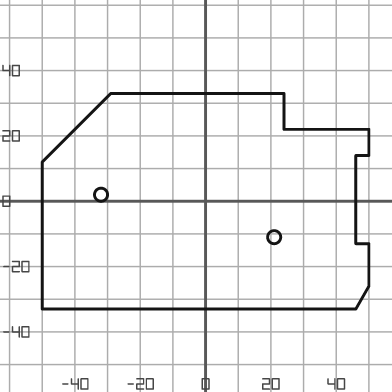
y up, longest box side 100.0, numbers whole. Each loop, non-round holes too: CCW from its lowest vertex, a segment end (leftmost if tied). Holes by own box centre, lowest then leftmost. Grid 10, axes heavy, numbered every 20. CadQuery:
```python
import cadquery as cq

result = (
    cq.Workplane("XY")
    .moveTo(-50.0, -33.0)
    .lineTo(46.0, -33.0)
    .lineTo(50.0, -26.0)
    .lineTo(50.0, -13.0)
    .lineTo(46.0, -13.0)
    .lineTo(46.0, 14.0)
    .lineTo(50.0, 14.0)
    .lineTo(50.0, 22.0)
    .lineTo(24.0, 22.0)
    .lineTo(24.0, 33.0)
    .lineTo(-29.0, 33.0)
    .lineTo(-50.0, 12.0)
    .close()
    .moveTo(21.0, -11.0)
    .circle(2.0)
    .moveTo(-32.0, 2.0)
    .circle(2.0)
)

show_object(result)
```